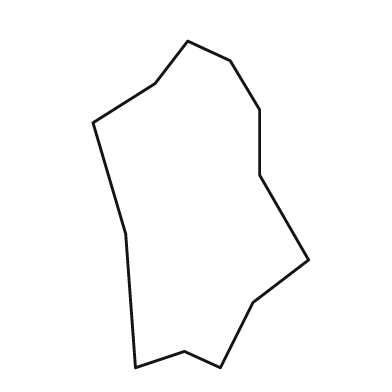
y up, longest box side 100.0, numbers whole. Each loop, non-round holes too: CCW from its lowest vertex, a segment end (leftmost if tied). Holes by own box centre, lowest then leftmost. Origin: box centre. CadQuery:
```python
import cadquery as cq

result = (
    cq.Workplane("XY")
    .moveTo(-20.0, -50.0)
    .lineTo(-5.0, -45.0)
    .lineTo(6.0, -50.0)
    .lineTo(16.0, -30.0)
    .lineTo(33.0, -17.0)
    .lineTo(18.0, 9.0)
    .lineTo(18.0, 29.0)
    .lineTo(9.0, 44.0)
    .lineTo(-4.0, 50.0)
    .lineTo(-14.0, 37.0)
    .lineTo(-33.0, 25.0)
    .lineTo(-23.0, -9.0)
    .close()
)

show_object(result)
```